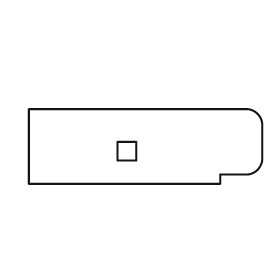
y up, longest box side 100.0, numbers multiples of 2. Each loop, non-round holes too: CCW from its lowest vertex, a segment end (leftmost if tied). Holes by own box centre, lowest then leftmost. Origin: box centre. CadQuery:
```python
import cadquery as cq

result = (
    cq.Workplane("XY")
    .moveTo(-50.0, -16.0)
    .lineTo(32.0, -16.0)
    .lineTo(32.0, -12.0)
    .lineTo(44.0, -12.0)
    .threePointArc((48.0, -10.0), (50.0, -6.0))
    .lineTo(50.0, 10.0)
    .threePointArc((48.0, 14.0), (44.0, 16.0))
    .lineTo(-50.0, 16.0)
    .close()
    .moveTo(-12.0, -6.0)
    .lineTo(-4.0, -6.0)
    .lineTo(-4.0, 2.0)
    .lineTo(-12.0, 2.0)
    .close()
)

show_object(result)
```